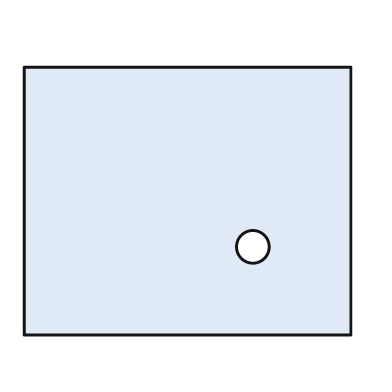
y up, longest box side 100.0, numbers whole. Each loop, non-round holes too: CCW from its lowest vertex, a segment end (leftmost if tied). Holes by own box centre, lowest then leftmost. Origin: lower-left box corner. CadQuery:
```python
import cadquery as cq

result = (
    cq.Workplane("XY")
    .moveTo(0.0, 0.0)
    .lineTo(100.0, 0.0)
    .lineTo(100.0, 82.0)
    .lineTo(0.0, 82.0)
    .close()
    .moveTo(70.0, 27.0)
    .circle(5.0)
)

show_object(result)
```